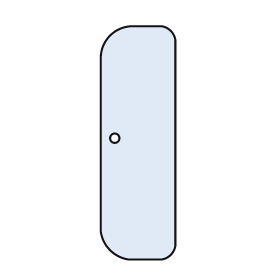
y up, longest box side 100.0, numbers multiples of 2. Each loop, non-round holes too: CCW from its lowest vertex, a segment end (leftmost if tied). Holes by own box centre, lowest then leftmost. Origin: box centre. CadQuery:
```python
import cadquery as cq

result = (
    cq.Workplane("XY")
    .moveTo(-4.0, -50.0)
    .lineTo(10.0, -50.0)
    .threePointArc((14.0, -48.0), (16.0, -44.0))
    .lineTo(16.0, 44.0)
    .threePointArc((14.0, 48.0), (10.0, 50.0))
    .lineTo(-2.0, 50.0)
    .threePointArc((-12.0, 46.0), (-16.0, 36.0))
    .lineTo(-16.0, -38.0)
    .threePointArc((-12.0, -46.0), (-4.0, -50.0))
    .close()
    .moveTo(-10.0, 2.0)
    .circle(2.0)
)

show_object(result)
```